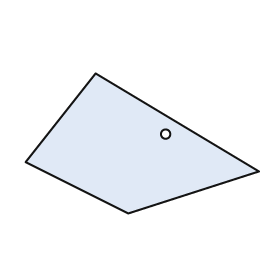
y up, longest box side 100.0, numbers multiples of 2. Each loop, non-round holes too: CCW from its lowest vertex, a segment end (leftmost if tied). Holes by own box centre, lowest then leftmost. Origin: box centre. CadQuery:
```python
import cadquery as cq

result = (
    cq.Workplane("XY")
    .moveTo(-6.0, -30.0)
    .lineTo(50.0, -12.0)
    .lineTo(-20.0, 30.0)
    .lineTo(-50.0, -8.0)
    .close()
    .moveTo(10.0, 4.0)
    .circle(2.0)
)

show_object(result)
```